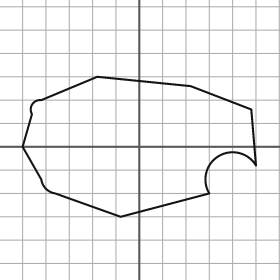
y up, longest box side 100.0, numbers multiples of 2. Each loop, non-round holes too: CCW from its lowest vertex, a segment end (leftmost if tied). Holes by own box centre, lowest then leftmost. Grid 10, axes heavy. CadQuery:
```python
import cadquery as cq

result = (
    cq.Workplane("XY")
    .moveTo(-8.0, -30.0)
    .lineTo(30.0, -20.0)
    .threePointArc((34.0, -4.0), (50.0, -8.0))
    .lineTo(48.0, 16.0)
    .lineTo(22.0, 26.0)
    .lineTo(-18.0, 30.0)
    .lineTo(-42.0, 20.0)
    .threePointArc((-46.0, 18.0), (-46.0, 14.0))
    .lineTo(-50.0, 0.0)
    .lineTo(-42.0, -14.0)
    .threePointArc((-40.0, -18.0), (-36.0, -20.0))
    .close()
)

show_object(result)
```